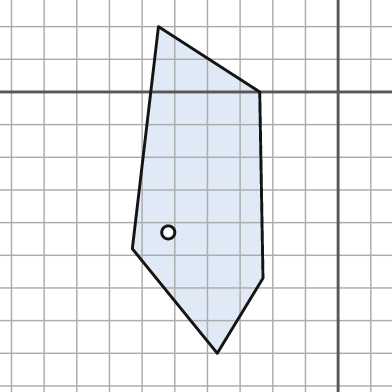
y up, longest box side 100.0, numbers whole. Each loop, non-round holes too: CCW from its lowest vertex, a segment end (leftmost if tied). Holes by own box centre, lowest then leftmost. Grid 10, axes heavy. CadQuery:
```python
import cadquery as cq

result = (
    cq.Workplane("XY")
    .moveTo(-37.0, -80.0)
    .lineTo(-23.0, -57.0)
    .lineTo(-24.0, 0.0)
    .lineTo(-55.0, 20.0)
    .lineTo(-63.0, -48.0)
    .close()
    .moveTo(-52.0, -43.0)
    .circle(2.0)
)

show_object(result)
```